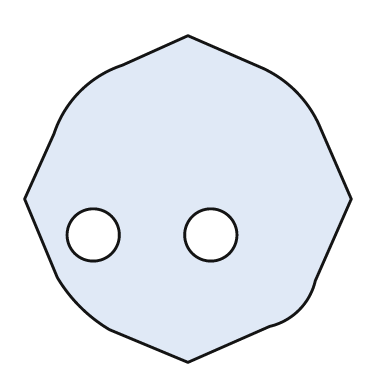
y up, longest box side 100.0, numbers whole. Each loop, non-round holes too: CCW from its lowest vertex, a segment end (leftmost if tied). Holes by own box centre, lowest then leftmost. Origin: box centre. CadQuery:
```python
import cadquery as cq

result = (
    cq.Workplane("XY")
    .moveTo(0.0, -50.0)
    .lineTo(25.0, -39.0)
    .threePointArc((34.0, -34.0), (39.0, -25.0))
    .lineTo(50.0, 0.0)
    .lineTo(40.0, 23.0)
    .threePointArc((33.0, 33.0), (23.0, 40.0))
    .lineTo(0.0, 50.0)
    .lineTo(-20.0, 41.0)
    .threePointArc((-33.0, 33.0), (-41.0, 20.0))
    .lineTo(-50.0, 0.0)
    .lineTo(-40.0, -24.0)
    .threePointArc((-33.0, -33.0), (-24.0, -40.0))
    .close()
    .moveTo(-29.0, -11.0)
    .circle(8.0)
    .moveTo(7.0, -11.0)
    .circle(8.0)
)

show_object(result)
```